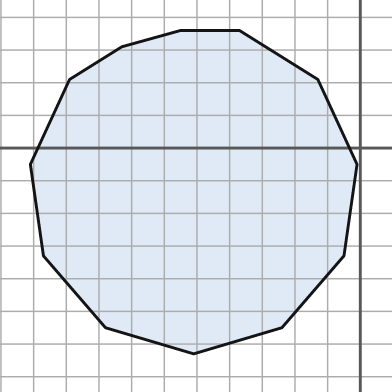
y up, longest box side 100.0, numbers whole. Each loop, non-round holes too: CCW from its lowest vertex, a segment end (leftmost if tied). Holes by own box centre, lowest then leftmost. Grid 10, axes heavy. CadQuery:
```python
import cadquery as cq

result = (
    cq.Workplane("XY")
    .moveTo(-51.0, -63.0)
    .lineTo(-24.0, -55.0)
    .lineTo(-5.0, -33.0)
    .lineTo(-1.0, -5.0)
    .lineTo(-13.0, 21.0)
    .lineTo(-37.0, 36.0)
    .lineTo(-55.0, 36.0)
    .lineTo(-73.0, 31.0)
    .lineTo(-89.0, 21.0)
    .lineTo(-101.0, -5.0)
    .lineTo(-97.0, -33.0)
    .lineTo(-78.0, -55.0)
    .close()
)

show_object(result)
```